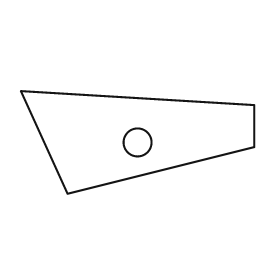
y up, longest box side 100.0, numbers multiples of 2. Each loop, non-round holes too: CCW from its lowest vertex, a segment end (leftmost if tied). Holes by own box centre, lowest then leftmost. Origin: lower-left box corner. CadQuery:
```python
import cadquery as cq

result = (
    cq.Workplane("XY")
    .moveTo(20.0, 0.0)
    .lineTo(100.0, 20.0)
    .lineTo(100.0, 38.0)
    .lineTo(0.0, 44.0)
    .close()
    .moveTo(50.0, 22.0)
    .circle(6.0)
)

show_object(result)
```